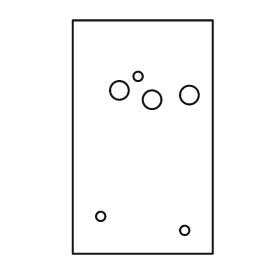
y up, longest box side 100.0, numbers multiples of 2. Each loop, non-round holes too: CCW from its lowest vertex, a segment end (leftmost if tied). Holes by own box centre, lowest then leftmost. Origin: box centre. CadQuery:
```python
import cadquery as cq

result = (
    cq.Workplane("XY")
    .moveTo(-30.0, -50.0)
    .lineTo(30.0, -50.0)
    .lineTo(30.0, 50.0)
    .lineTo(-30.0, 50.0)
    .close()
    .moveTo(18.0, -40.0)
    .circle(2.0)
    .moveTo(-18.0, -34.0)
    .circle(2.0)
    .moveTo(4.0, 16.0)
    .circle(4.0)
    .moveTo(20.0, 18.0)
    .circle(4.0)
    .moveTo(-10.0, 20.0)
    .circle(4.0)
    .moveTo(-2.0, 26.0)
    .circle(2.0)
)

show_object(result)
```